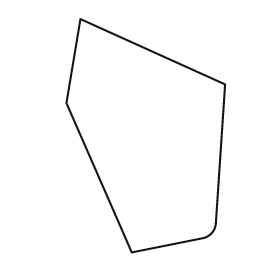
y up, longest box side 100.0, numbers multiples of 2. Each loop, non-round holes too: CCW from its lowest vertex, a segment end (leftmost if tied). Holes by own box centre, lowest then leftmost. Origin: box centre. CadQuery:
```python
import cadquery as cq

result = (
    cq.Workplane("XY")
    .moveTo(-6.0, -50.0)
    .lineTo(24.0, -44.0)
    .threePointArc((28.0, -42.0), (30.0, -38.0))
    .lineTo(34.0, 22.0)
    .lineTo(-28.0, 50.0)
    .lineTo(-34.0, 14.0)
    .close()
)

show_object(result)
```